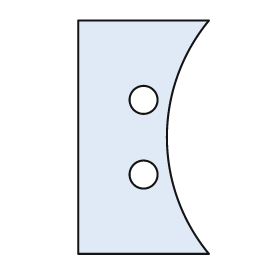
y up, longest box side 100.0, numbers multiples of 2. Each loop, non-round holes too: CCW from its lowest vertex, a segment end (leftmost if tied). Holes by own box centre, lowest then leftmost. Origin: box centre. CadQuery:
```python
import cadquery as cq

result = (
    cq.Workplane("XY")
    .moveTo(-28.0, -50.0)
    .lineTo(28.0, -50.0)
    .threePointArc((10.0, 0.0), (28.0, 50.0))
    .lineTo(-28.0, 50.0)
    .close()
    .moveTo(0.0, -16.0)
    .circle(6.0)
    .moveTo(0.0, 16.0)
    .circle(6.0)
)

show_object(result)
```